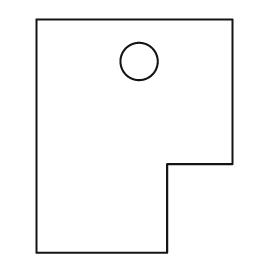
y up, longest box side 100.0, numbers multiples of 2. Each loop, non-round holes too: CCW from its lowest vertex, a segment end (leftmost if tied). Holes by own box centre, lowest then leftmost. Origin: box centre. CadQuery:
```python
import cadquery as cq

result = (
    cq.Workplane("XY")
    .moveTo(-42.0, -50.0)
    .lineTo(14.0, -50.0)
    .lineTo(14.0, -12.0)
    .lineTo(42.0, -12.0)
    .lineTo(42.0, 50.0)
    .lineTo(-42.0, 50.0)
    .close()
    .moveTo(2.0, 32.0)
    .circle(8.0)
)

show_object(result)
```